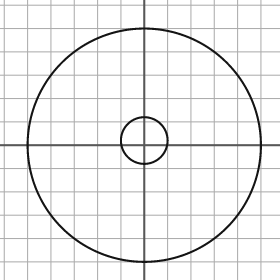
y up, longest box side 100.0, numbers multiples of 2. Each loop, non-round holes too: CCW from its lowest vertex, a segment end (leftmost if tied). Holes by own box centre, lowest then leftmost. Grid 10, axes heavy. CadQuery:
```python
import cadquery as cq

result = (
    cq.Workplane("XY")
    .moveTo(0.0, 0.0)
    .circle(50.0)
    .moveTo(0.0, 2.0)
    .circle(10.0)
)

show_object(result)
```